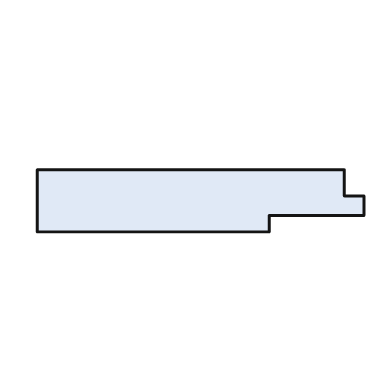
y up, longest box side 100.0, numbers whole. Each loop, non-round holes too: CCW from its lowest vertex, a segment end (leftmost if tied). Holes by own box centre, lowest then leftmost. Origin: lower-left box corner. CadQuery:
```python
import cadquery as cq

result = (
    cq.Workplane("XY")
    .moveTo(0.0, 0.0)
    .lineTo(71.0, 0.0)
    .lineTo(71.0, 5.0)
    .lineTo(100.0, 5.0)
    .lineTo(100.0, 11.0)
    .lineTo(94.0, 11.0)
    .lineTo(94.0, 19.0)
    .lineTo(0.0, 19.0)
    .close()
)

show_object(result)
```